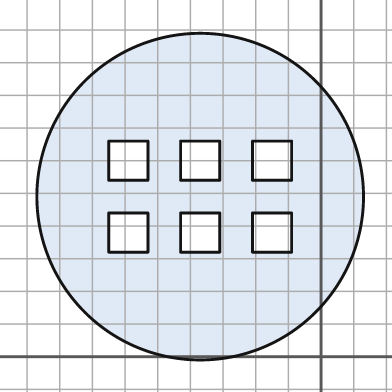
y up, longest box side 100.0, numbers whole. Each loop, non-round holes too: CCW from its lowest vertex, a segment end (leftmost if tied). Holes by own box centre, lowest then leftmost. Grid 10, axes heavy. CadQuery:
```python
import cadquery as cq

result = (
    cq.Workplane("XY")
    .moveTo(-37.0, 49.0)
    .circle(50.0)
    .moveTo(-65.0, 32.0)
    .lineTo(-53.0, 32.0)
    .lineTo(-53.0, 44.0)
    .lineTo(-65.0, 44.0)
    .close()
    .moveTo(-43.0, 32.0)
    .lineTo(-31.0, 32.0)
    .lineTo(-31.0, 44.0)
    .lineTo(-43.0, 44.0)
    .close()
    .moveTo(-21.0, 32.0)
    .lineTo(-9.0, 32.0)
    .lineTo(-9.0, 44.0)
    .lineTo(-21.0, 44.0)
    .close()
    .moveTo(-65.0, 54.0)
    .lineTo(-53.0, 54.0)
    .lineTo(-53.0, 66.0)
    .lineTo(-65.0, 66.0)
    .close()
    .moveTo(-43.0, 54.0)
    .lineTo(-31.0, 54.0)
    .lineTo(-31.0, 66.0)
    .lineTo(-43.0, 66.0)
    .close()
    .moveTo(-21.0, 54.0)
    .lineTo(-9.0, 54.0)
    .lineTo(-9.0, 66.0)
    .lineTo(-21.0, 66.0)
    .close()
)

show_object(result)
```